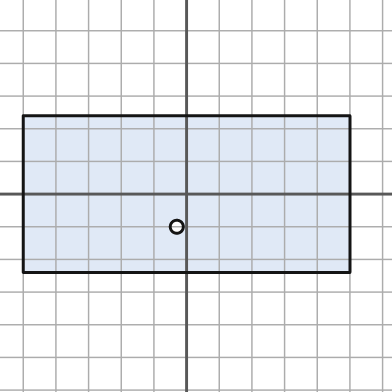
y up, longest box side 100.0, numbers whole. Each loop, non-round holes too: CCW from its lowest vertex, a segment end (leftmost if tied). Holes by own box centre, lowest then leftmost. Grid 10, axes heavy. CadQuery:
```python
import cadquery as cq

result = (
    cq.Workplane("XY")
    .moveTo(-50.0, -24.0)
    .lineTo(50.0, -24.0)
    .lineTo(50.0, 24.0)
    .lineTo(-50.0, 24.0)
    .close()
    .moveTo(-3.0, -10.0)
    .circle(2.0)
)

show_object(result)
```